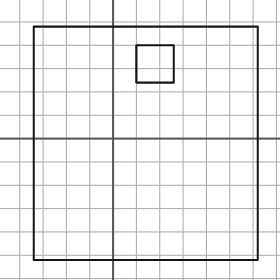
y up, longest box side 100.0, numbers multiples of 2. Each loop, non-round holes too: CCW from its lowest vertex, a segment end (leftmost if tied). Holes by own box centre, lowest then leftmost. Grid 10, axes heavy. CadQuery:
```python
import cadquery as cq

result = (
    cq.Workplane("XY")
    .moveTo(-34.0, -52.0)
    .lineTo(62.0, -52.0)
    .lineTo(62.0, 48.0)
    .lineTo(-34.0, 48.0)
    .close()
    .moveTo(10.0, 24.0)
    .lineTo(26.0, 24.0)
    .lineTo(26.0, 40.0)
    .lineTo(10.0, 40.0)
    .close()
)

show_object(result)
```